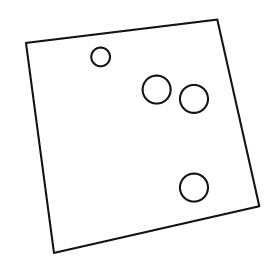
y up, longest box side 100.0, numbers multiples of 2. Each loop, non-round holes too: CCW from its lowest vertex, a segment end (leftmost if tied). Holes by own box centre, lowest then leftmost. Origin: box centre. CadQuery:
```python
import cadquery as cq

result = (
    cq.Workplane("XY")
    .moveTo(-38.0, -50.0)
    .lineTo(50.0, -30.0)
    .lineTo(32.0, 50.0)
    .lineTo(-50.0, 40.0)
    .close()
    .moveTo(22.0, -22.0)
    .circle(6.0)
    .moveTo(22.0, 16.0)
    .circle(6.0)
    .moveTo(6.0, 20.0)
    .circle(6.0)
    .moveTo(-18.0, 34.0)
    .circle(4.0)
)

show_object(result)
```